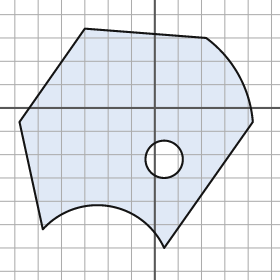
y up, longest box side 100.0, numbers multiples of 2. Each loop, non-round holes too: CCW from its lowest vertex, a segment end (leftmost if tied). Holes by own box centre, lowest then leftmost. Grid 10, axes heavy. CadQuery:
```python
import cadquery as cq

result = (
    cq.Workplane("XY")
    .moveTo(4.0, -60.0)
    .lineTo(42.0, -6.0)
    .threePointArc((36.0, 14.0), (22.0, 30.0))
    .lineTo(-30.0, 34.0)
    .lineTo(-58.0, -6.0)
    .lineTo(-48.0, -52.0)
    .threePointArc((-20.0, -42.0), (4.0, -60.0))
    .close()
    .moveTo(4.0, -22.0)
    .circle(8.0)
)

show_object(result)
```